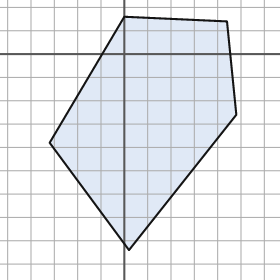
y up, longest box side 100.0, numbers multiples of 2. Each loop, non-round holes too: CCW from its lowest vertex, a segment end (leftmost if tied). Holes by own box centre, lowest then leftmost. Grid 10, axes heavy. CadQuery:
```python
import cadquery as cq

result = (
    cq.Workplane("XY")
    .moveTo(2.0, -84.0)
    .lineTo(48.0, -26.0)
    .lineTo(44.0, 14.0)
    .lineTo(0.0, 16.0)
    .lineTo(-32.0, -38.0)
    .close()
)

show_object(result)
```